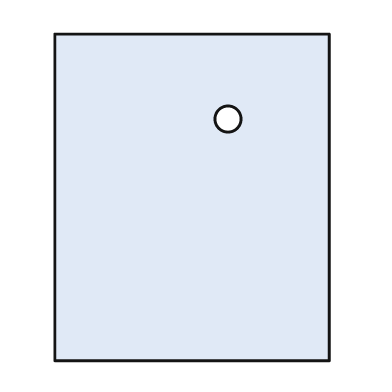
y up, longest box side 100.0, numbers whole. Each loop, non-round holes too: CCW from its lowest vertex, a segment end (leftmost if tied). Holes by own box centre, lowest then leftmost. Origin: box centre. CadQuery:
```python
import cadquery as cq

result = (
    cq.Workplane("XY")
    .moveTo(-42.0, -50.0)
    .lineTo(42.0, -50.0)
    .lineTo(42.0, 50.0)
    .lineTo(-42.0, 50.0)
    .close()
    .moveTo(11.0, 24.0)
    .circle(4.0)
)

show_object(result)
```